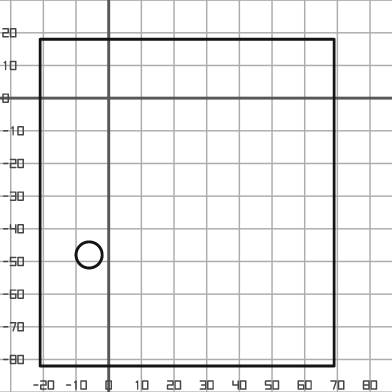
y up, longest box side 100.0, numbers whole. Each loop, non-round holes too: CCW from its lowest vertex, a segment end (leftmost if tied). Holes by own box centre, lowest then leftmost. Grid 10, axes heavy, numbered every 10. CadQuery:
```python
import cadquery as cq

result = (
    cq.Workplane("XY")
    .moveTo(-21.0, -82.0)
    .lineTo(69.0, -82.0)
    .lineTo(69.0, 18.0)
    .lineTo(-21.0, 18.0)
    .close()
    .moveTo(-6.0, -48.0)
    .circle(4.0)
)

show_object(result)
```